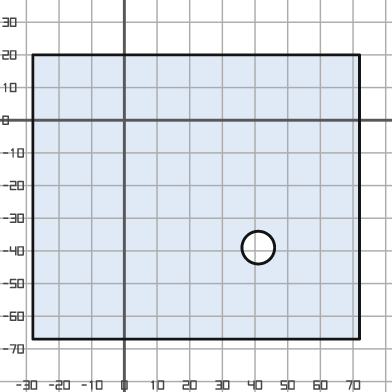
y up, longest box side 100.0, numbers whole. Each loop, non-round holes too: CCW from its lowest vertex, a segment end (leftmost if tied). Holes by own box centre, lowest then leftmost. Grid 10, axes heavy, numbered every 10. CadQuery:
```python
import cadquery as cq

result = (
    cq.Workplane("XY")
    .moveTo(-28.0, -67.0)
    .lineTo(72.0, -67.0)
    .lineTo(72.0, 20.0)
    .lineTo(-28.0, 20.0)
    .close()
    .moveTo(41.0, -39.0)
    .circle(5.0)
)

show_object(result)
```